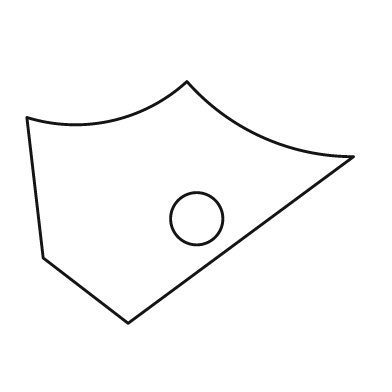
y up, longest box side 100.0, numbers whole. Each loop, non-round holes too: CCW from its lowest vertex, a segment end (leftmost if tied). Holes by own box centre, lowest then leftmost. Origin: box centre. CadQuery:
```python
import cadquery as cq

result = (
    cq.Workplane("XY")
    .moveTo(-19.0, -37.0)
    .lineTo(50.0, 14.0)
    .threePointArc((22.0, 20.0), (-1.0, 37.0))
    .threePointArc((-24.0, 25.0), (-50.0, 26.0))
    .lineTo(-45.0, -17.0)
    .close()
    .moveTo(2.0, -5.0)
    .circle(8.0)
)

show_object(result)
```